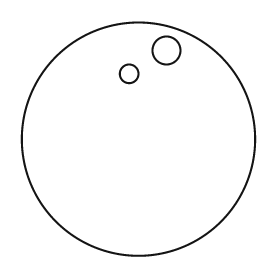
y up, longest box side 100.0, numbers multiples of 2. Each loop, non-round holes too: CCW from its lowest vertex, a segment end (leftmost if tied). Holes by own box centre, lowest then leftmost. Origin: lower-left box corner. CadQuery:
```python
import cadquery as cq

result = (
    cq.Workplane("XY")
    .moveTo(50.0, 50.0)
    .circle(50.0)
    .moveTo(46.0, 78.0)
    .circle(4.0)
    .moveTo(62.0, 88.0)
    .circle(6.0)
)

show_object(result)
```